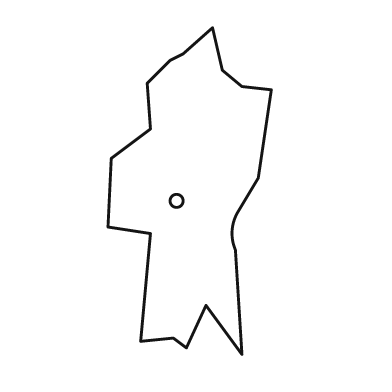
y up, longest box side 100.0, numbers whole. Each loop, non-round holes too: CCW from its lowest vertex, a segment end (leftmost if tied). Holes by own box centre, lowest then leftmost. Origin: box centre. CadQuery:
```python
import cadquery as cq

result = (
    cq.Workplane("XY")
    .moveTo(16.0, -50.0)
    .lineTo(14.0, -18.0)
    .threePointArc((13.0, -12.0), (15.0, -6.0))
    .lineTo(21.0, 4.0)
    .lineTo(25.0, 31.0)
    .lineTo(16.0, 32.0)
    .lineTo(10.0, 37.0)
    .lineTo(7.0, 50.0)
    .lineTo(-2.0, 42.0)
    .lineTo(-6.0, 40.0)
    .lineTo(-13.0, 33.0)
    .lineTo(-12.0, 19.0)
    .lineTo(-24.0, 10.0)
    .lineTo(-25.0, -11.0)
    .lineTo(-12.0, -13.0)
    .lineTo(-15.0, -46.0)
    .lineTo(-5.0, -45.0)
    .lineTo(-1.0, -48.0)
    .lineTo(5.0, -35.0)
    .close()
    .moveTo(-4.0, -3.0)
    .circle(2.0)
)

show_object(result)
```